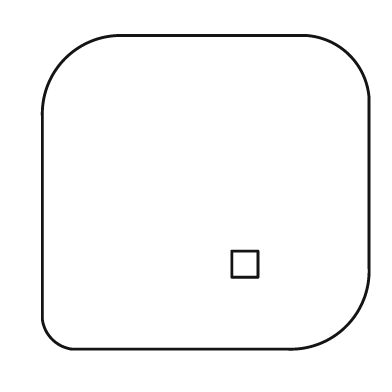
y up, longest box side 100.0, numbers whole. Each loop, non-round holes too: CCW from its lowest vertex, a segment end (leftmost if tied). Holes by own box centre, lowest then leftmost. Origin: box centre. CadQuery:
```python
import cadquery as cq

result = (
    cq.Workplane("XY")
    .moveTo(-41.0, -48.0)
    .lineTo(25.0, -48.0)
    .threePointArc((43.0, -41.0), (50.0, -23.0))
    .lineTo(50.0, 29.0)
    .threePointArc((44.0, 42.0), (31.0, 48.0))
    .lineTo(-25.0, 48.0)
    .threePointArc((-43.0, 41.0), (-50.0, 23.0))
    .lineTo(-50.0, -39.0)
    .threePointArc((-47.0, -45.0), (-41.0, -48.0))
    .close()
    .moveTo(8.0, -26.0)
    .lineTo(16.0, -26.0)
    .lineTo(16.0, -18.0)
    .lineTo(8.0, -18.0)
    .close()
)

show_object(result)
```